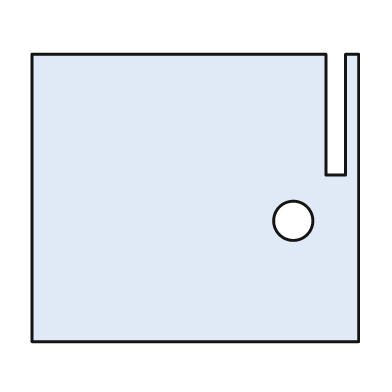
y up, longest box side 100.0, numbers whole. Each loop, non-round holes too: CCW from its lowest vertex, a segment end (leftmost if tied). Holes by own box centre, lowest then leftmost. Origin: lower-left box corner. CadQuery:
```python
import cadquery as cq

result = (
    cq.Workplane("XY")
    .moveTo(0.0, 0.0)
    .lineTo(100.0, 0.0)
    .lineTo(100.0, 88.0)
    .lineTo(96.0, 88.0)
    .lineTo(96.0, 51.0)
    .lineTo(90.0, 51.0)
    .lineTo(90.0, 88.0)
    .lineTo(0.0, 88.0)
    .close()
    .moveTo(80.0, 37.0)
    .circle(6.0)
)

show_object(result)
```